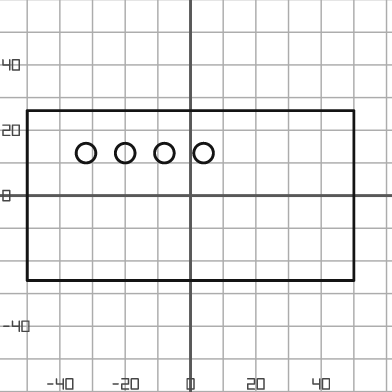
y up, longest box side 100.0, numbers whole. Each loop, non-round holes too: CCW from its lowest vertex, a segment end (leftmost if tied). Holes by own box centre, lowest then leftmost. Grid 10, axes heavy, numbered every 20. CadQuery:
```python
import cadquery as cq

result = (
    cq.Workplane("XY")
    .moveTo(-50.0, -26.0)
    .lineTo(50.0, -26.0)
    .lineTo(50.0, 26.0)
    .lineTo(-50.0, 26.0)
    .close()
    .moveTo(-32.0, 13.0)
    .circle(3.0)
    .moveTo(-20.0, 13.0)
    .circle(3.0)
    .moveTo(-8.0, 13.0)
    .circle(3.0)
    .moveTo(4.0, 13.0)
    .circle(3.0)
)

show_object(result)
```